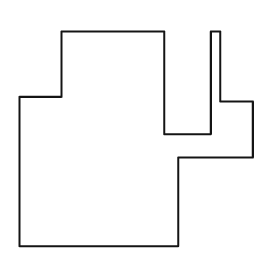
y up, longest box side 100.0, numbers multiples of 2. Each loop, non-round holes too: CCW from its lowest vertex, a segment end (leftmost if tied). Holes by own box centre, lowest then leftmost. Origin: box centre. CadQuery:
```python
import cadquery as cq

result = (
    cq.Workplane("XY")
    .moveTo(-50.0, -46.0)
    .lineTo(18.0, -46.0)
    .lineTo(18.0, -8.0)
    .lineTo(50.0, -8.0)
    .lineTo(50.0, 16.0)
    .lineTo(36.0, 16.0)
    .lineTo(36.0, 46.0)
    .lineTo(32.0, 46.0)
    .lineTo(32.0, 2.0)
    .lineTo(12.0, 2.0)
    .lineTo(12.0, 46.0)
    .lineTo(-32.0, 46.0)
    .lineTo(-32.0, 18.0)
    .lineTo(-50.0, 18.0)
    .close()
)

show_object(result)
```